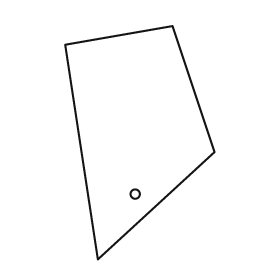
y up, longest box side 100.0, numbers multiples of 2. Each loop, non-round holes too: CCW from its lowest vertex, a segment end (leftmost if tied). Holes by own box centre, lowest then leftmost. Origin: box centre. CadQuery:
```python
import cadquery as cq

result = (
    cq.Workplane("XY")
    .moveTo(-18.0, -50.0)
    .lineTo(32.0, -4.0)
    .lineTo(14.0, 50.0)
    .lineTo(-32.0, 42.0)
    .close()
    .moveTo(-2.0, -22.0)
    .circle(2.0)
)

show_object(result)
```